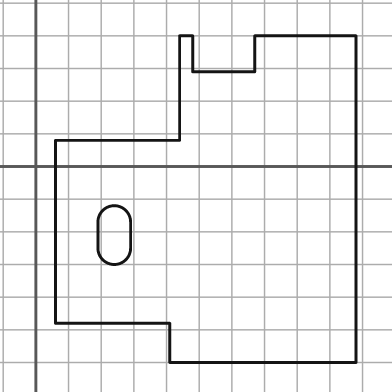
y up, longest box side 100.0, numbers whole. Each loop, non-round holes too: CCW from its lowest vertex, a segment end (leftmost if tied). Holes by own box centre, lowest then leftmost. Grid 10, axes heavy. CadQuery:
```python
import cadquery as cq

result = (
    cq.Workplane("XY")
    .moveTo(41.0, -60.0)
    .lineTo(98.0, -60.0)
    .lineTo(98.0, 40.0)
    .lineTo(67.0, 40.0)
    .lineTo(67.0, 29.0)
    .lineTo(48.0, 29.0)
    .lineTo(48.0, 40.0)
    .lineTo(44.0, 40.0)
    .lineTo(44.0, 8.0)
    .lineTo(6.0, 8.0)
    .lineTo(6.0, -48.0)
    .lineTo(41.0, -48.0)
    .close()
    .moveTo(19.0, -25.0)
    .threePointArc((24.0, -30.0), (29.0, -25.0))
    .lineTo(29.0, -17.0)
    .threePointArc((24.0, -12.0), (19.0, -17.0))
    .close()
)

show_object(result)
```